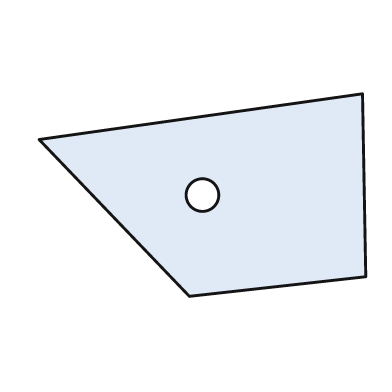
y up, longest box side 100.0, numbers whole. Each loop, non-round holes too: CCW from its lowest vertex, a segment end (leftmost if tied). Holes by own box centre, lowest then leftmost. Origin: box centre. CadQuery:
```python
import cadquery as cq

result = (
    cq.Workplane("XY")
    .moveTo(-4.0, -31.0)
    .lineTo(50.0, -25.0)
    .lineTo(49.0, 31.0)
    .lineTo(-50.0, 17.0)
    .close()
    .moveTo(0.0, 0.0)
    .circle(5.0)
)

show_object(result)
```